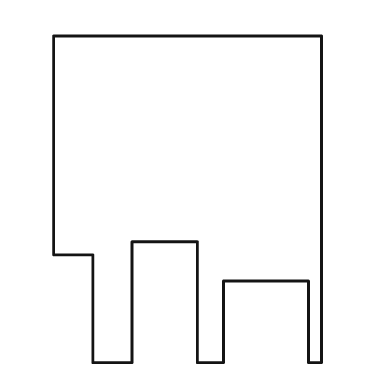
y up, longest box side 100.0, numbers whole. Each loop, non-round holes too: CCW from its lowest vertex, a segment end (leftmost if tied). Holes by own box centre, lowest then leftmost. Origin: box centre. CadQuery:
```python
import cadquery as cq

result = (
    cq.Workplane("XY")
    .moveTo(-29.0, -50.0)
    .lineTo(-17.0, -50.0)
    .lineTo(-17.0, -13.0)
    .lineTo(3.0, -13.0)
    .lineTo(3.0, -50.0)
    .lineTo(11.0, -50.0)
    .lineTo(11.0, -25.0)
    .lineTo(37.0, -25.0)
    .lineTo(37.0, -50.0)
    .lineTo(41.0, -50.0)
    .lineTo(41.0, 50.0)
    .lineTo(-41.0, 50.0)
    .lineTo(-41.0, -17.0)
    .lineTo(-29.0, -17.0)
    .close()
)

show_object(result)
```